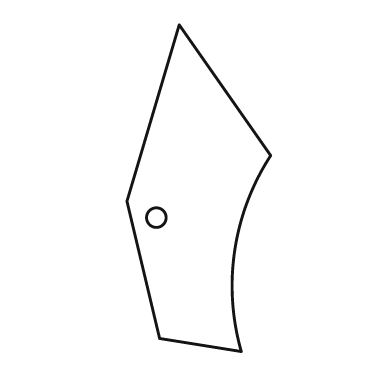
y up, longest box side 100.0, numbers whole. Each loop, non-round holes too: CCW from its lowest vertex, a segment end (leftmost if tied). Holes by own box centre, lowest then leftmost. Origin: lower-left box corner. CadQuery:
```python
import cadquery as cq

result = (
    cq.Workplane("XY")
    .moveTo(35.0, 0.0)
    .threePointArc((33.0, 31.0), (44.0, 60.0))
    .lineTo(16.0, 100.0)
    .lineTo(0.0, 46.0)
    .lineTo(10.0, 4.0)
    .close()
    .moveTo(9.0, 41.0)
    .circle(3.0)
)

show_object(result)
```